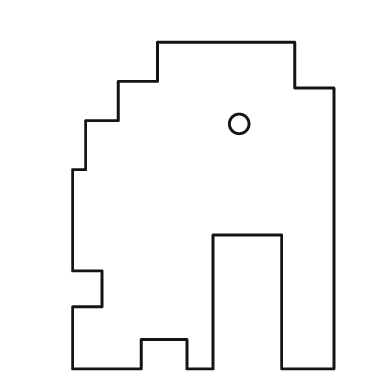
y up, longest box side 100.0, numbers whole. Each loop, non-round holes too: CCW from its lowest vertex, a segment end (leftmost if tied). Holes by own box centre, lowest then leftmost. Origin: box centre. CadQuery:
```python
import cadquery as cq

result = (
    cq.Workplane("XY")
    .moveTo(-40.0, -50.0)
    .lineTo(-19.0, -50.0)
    .lineTo(-19.0, -41.0)
    .lineTo(-5.0, -41.0)
    .lineTo(-5.0, -50.0)
    .lineTo(3.0, -50.0)
    .lineTo(3.0, -9.0)
    .lineTo(24.0, -9.0)
    .lineTo(24.0, -50.0)
    .lineTo(40.0, -50.0)
    .lineTo(40.0, 36.0)
    .lineTo(28.0, 36.0)
    .lineTo(28.0, 50.0)
    .lineTo(-14.0, 50.0)
    .lineTo(-14.0, 38.0)
    .lineTo(-26.0, 38.0)
    .lineTo(-26.0, 26.0)
    .lineTo(-36.0, 26.0)
    .lineTo(-36.0, 11.0)
    .lineTo(-40.0, 11.0)
    .lineTo(-40.0, -20.0)
    .lineTo(-31.0, -20.0)
    .lineTo(-31.0, -31.0)
    .lineTo(-40.0, -31.0)
    .close()
    .moveTo(11.0, 25.0)
    .circle(3.0)
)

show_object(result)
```